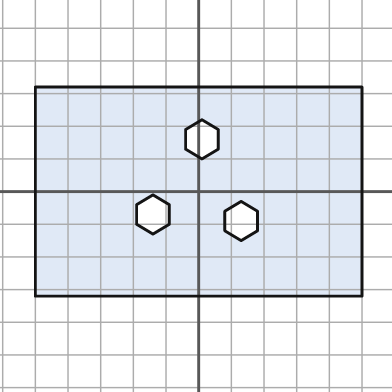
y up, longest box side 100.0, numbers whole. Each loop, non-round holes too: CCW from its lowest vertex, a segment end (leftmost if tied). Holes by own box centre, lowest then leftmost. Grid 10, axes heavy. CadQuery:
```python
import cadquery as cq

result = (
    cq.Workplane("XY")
    .moveTo(-50.0, -32.0)
    .lineTo(50.0, -32.0)
    .lineTo(50.0, 32.0)
    .lineTo(-50.0, 32.0)
    .close()
    .moveTo(13.0, -15.0)
    .lineTo(18.0, -12.0)
    .lineTo(18.0, -6.0)
    .lineTo(13.0, -3.0)
    .lineTo(8.0, -6.0)
    .lineTo(8.0, -12.0)
    .close()
    .moveTo(-14.0, -13.0)
    .lineTo(-9.0, -10.0)
    .lineTo(-9.0, -4.0)
    .lineTo(-14.0, -1.0)
    .lineTo(-19.0, -4.0)
    .lineTo(-19.0, -10.0)
    .close()
    .moveTo(1.0, 10.0)
    .lineTo(6.0, 13.0)
    .lineTo(6.0, 19.0)
    .lineTo(1.0, 22.0)
    .lineTo(-4.0, 19.0)
    .lineTo(-4.0, 13.0)
    .close()
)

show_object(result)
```